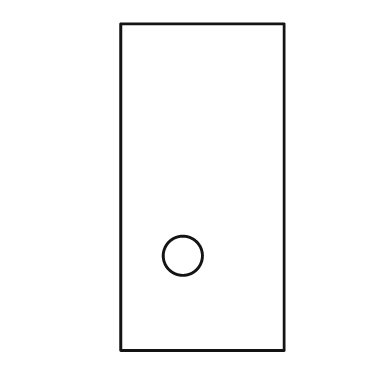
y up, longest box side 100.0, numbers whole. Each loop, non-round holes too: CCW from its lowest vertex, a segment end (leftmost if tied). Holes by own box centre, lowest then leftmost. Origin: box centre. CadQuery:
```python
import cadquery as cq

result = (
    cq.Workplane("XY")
    .moveTo(-25.0, -50.0)
    .lineTo(25.0, -50.0)
    .lineTo(25.0, 50.0)
    .lineTo(-25.0, 50.0)
    .close()
    .moveTo(-6.0, -21.0)
    .circle(6.0)
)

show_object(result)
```